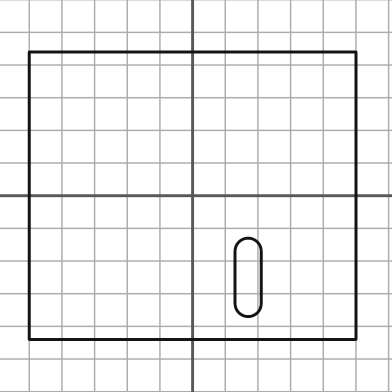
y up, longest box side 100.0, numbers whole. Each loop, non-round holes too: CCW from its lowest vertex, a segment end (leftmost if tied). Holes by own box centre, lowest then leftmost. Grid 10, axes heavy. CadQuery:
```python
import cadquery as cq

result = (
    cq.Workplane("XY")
    .moveTo(-50.0, -44.0)
    .lineTo(50.0, -44.0)
    .lineTo(50.0, 44.0)
    .lineTo(-50.0, 44.0)
    .close()
    .moveTo(13.0, -33.0)
    .threePointArc((17.0, -37.0), (21.0, -33.0))
    .lineTo(21.0, -17.0)
    .threePointArc((17.0, -13.0), (13.0, -17.0))
    .close()
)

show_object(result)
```